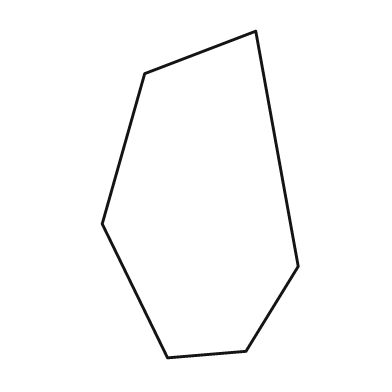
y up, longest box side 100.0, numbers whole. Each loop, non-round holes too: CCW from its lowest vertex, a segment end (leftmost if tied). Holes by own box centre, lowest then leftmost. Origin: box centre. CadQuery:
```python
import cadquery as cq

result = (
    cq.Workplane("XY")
    .moveTo(-10.0, -50.0)
    .lineTo(14.0, -48.0)
    .lineTo(30.0, -22.0)
    .lineTo(17.0, 50.0)
    .lineTo(-17.0, 37.0)
    .lineTo(-30.0, -9.0)
    .close()
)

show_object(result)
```